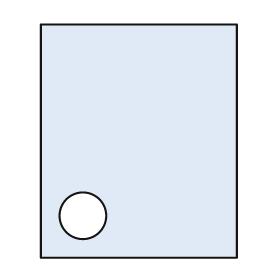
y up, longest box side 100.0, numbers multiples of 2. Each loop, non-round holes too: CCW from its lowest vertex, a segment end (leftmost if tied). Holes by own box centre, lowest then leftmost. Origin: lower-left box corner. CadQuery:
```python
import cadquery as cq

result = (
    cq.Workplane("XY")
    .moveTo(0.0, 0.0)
    .lineTo(84.0, 0.0)
    .lineTo(84.0, 100.0)
    .lineTo(0.0, 100.0)
    .close()
    .moveTo(18.0, 18.0)
    .circle(10.0)
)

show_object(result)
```